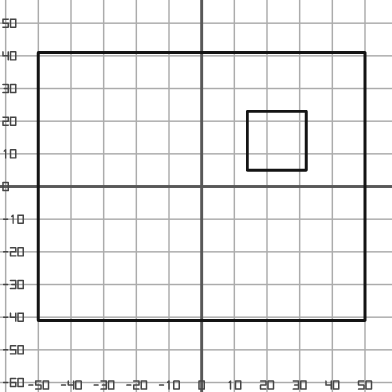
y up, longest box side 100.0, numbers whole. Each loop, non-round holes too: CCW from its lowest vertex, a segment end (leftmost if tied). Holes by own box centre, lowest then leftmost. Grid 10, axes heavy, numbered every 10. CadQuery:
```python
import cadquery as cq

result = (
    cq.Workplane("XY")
    .moveTo(-50.0, -41.0)
    .lineTo(50.0, -41.0)
    .lineTo(50.0, 41.0)
    .lineTo(-50.0, 41.0)
    .close()
    .moveTo(14.0, 5.0)
    .lineTo(32.0, 5.0)
    .lineTo(32.0, 23.0)
    .lineTo(14.0, 23.0)
    .close()
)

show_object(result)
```